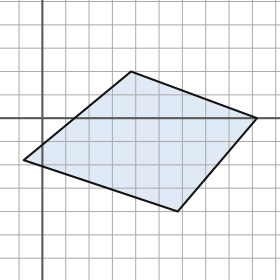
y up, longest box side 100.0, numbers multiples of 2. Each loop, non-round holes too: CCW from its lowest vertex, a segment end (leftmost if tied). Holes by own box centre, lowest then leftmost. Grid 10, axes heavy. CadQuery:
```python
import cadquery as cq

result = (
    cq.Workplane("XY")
    .moveTo(58.0, -40.0)
    .lineTo(92.0, 0.0)
    .lineTo(38.0, 20.0)
    .lineTo(-8.0, -18.0)
    .close()
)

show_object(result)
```